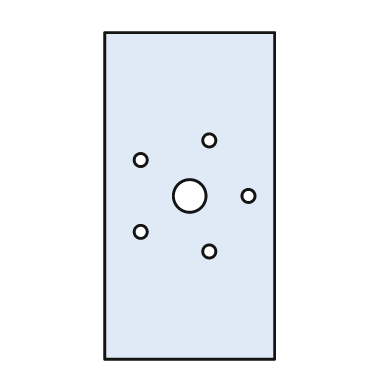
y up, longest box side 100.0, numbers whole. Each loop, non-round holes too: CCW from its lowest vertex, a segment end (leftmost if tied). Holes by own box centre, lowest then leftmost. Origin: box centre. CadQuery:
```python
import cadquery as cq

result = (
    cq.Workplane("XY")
    .moveTo(-26.0, -50.0)
    .lineTo(26.0, -50.0)
    .lineTo(26.0, 50.0)
    .lineTo(-26.0, 50.0)
    .close()
    .moveTo(6.0, -17.0)
    .circle(2.0)
    .moveTo(-15.0, -11.0)
    .circle(2.0)
    .moveTo(0.0, 0.0)
    .circle(5.0)
    .moveTo(18.0, 0.0)
    .circle(2.0)
    .moveTo(-15.0, 11.0)
    .circle(2.0)
    .moveTo(6.0, 17.0)
    .circle(2.0)
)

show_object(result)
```